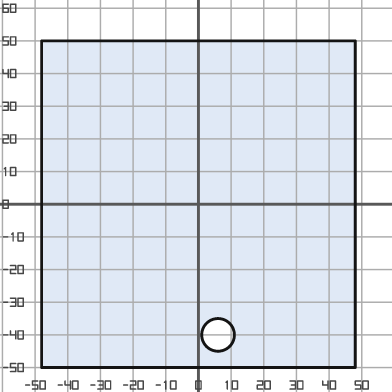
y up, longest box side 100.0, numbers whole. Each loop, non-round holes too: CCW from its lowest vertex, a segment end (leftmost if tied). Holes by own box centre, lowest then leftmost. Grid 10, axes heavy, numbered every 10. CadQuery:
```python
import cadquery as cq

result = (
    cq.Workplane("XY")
    .moveTo(-48.0, -50.0)
    .lineTo(48.0, -50.0)
    .lineTo(48.0, 50.0)
    .lineTo(-48.0, 50.0)
    .close()
    .moveTo(6.0, -40.0)
    .circle(5.0)
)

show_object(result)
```